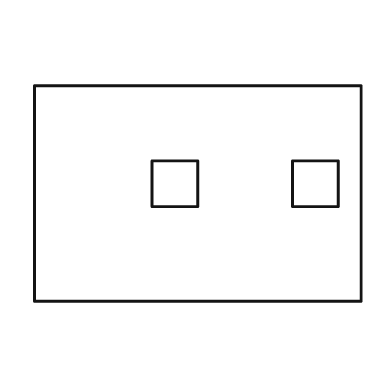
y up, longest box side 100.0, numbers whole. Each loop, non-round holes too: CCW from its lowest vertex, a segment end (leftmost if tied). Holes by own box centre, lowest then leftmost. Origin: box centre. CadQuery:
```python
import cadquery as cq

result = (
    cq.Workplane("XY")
    .moveTo(-50.0, -33.0)
    .lineTo(50.0, -33.0)
    .lineTo(50.0, 33.0)
    .lineTo(-50.0, 33.0)
    .close()
    .moveTo(-14.0, -4.0)
    .lineTo(0.0, -4.0)
    .lineTo(0.0, 10.0)
    .lineTo(-14.0, 10.0)
    .close()
    .moveTo(29.0, -4.0)
    .lineTo(43.0, -4.0)
    .lineTo(43.0, 10.0)
    .lineTo(29.0, 10.0)
    .close()
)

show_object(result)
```